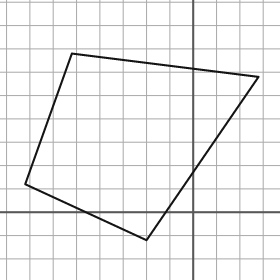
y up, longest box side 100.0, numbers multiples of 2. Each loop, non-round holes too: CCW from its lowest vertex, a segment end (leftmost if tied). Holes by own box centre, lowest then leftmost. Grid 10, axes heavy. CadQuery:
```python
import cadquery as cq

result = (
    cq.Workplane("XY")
    .moveTo(-20.0, -12.0)
    .lineTo(28.0, 58.0)
    .lineTo(-52.0, 68.0)
    .lineTo(-72.0, 12.0)
    .close()
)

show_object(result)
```